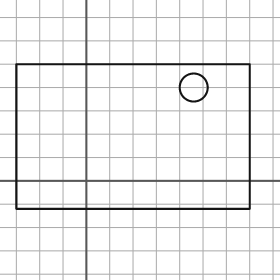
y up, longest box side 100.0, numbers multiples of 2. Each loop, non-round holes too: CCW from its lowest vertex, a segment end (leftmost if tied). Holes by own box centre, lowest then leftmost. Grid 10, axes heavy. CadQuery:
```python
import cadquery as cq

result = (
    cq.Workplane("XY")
    .moveTo(-30.0, -12.0)
    .lineTo(70.0, -12.0)
    .lineTo(70.0, 50.0)
    .lineTo(-30.0, 50.0)
    .close()
    .moveTo(46.0, 40.0)
    .circle(6.0)
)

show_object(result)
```